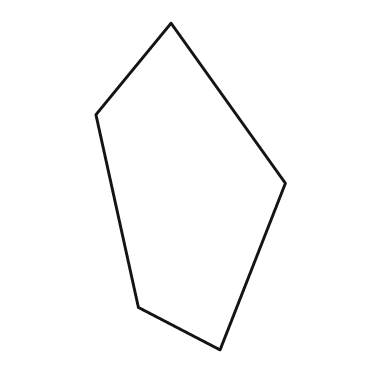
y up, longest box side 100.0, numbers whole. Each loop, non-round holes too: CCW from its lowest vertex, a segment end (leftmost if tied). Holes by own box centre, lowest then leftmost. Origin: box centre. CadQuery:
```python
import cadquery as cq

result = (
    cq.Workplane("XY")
    .moveTo(9.0, -50.0)
    .lineTo(29.0, 1.0)
    .lineTo(-6.0, 50.0)
    .lineTo(-29.0, 22.0)
    .lineTo(-16.0, -37.0)
    .close()
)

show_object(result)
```